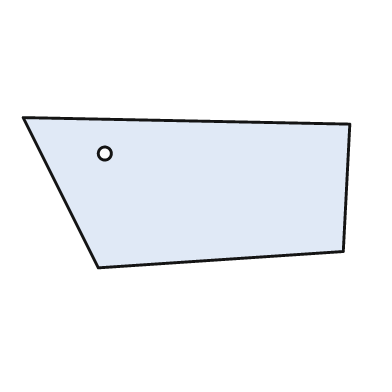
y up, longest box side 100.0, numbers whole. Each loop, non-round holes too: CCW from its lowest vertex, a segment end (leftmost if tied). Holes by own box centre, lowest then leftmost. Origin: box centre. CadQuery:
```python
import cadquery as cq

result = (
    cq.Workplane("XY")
    .moveTo(-27.0, -23.0)
    .lineTo(48.0, -18.0)
    .lineTo(50.0, 21.0)
    .lineTo(-50.0, 23.0)
    .close()
    .moveTo(-25.0, 12.0)
    .circle(2.0)
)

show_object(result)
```